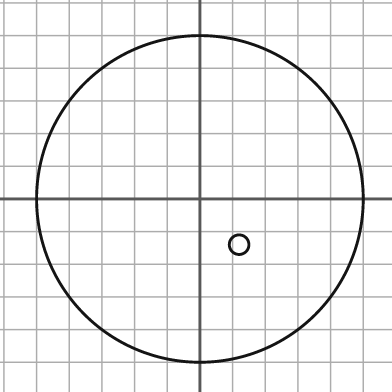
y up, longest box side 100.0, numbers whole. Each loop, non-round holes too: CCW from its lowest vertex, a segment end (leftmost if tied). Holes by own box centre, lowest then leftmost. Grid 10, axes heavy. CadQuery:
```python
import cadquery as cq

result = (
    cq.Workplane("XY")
    .moveTo(0.0, 0.0)
    .circle(50.0)
    .moveTo(12.0, -14.0)
    .circle(3.0)
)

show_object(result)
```